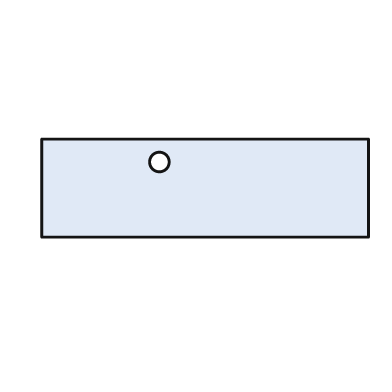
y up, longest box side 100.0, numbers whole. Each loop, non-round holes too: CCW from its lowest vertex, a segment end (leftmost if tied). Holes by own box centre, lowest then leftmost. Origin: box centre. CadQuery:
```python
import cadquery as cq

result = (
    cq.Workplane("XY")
    .moveTo(-50.0, -15.0)
    .lineTo(50.0, -15.0)
    .lineTo(50.0, 15.0)
    .lineTo(-50.0, 15.0)
    .close()
    .moveTo(-14.0, 8.0)
    .circle(3.0)
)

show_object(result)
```